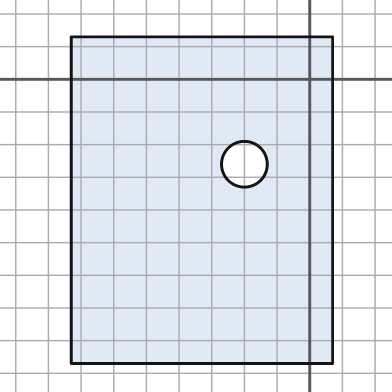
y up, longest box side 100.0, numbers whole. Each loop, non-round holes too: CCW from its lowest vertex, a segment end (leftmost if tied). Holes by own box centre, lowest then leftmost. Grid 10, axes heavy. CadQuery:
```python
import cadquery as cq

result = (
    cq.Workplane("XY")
    .moveTo(-73.0, -87.0)
    .lineTo(7.0, -87.0)
    .lineTo(7.0, 13.0)
    .lineTo(-73.0, 13.0)
    .close()
    .moveTo(-20.0, -26.0)
    .circle(7.0)
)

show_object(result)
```